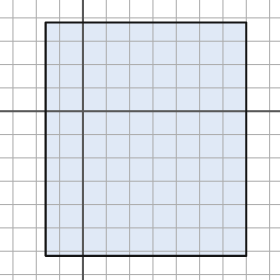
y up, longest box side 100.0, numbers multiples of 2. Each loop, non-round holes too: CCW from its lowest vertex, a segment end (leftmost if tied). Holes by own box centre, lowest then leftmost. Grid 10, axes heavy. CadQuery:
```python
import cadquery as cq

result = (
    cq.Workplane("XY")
    .moveTo(-16.0, -62.0)
    .lineTo(70.0, -62.0)
    .lineTo(70.0, 38.0)
    .lineTo(-16.0, 38.0)
    .close()
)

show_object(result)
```